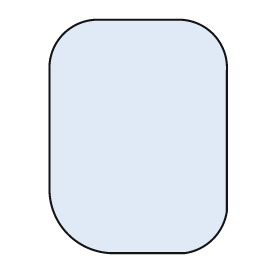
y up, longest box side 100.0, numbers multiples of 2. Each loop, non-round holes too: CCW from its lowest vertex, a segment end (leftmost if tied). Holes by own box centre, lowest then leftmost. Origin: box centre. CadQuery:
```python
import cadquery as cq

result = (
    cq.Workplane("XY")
    .moveTo(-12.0, -50.0)
    .lineTo(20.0, -50.0)
    .threePointArc((32.0, -44.0), (38.0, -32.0))
    .lineTo(38.0, 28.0)
    .threePointArc((32.0, 44.0), (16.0, 50.0))
    .lineTo(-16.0, 50.0)
    .threePointArc((-32.0, 44.0), (-38.0, 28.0))
    .lineTo(-38.0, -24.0)
    .threePointArc((-30.0, -42.0), (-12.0, -50.0))
    .close()
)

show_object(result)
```